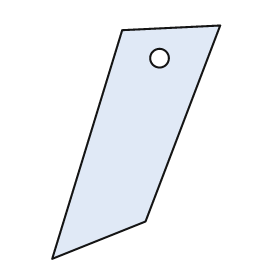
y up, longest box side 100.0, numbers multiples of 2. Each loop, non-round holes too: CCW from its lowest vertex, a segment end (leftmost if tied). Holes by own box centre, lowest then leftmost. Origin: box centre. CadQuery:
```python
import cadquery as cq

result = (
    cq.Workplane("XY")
    .moveTo(-36.0, -50.0)
    .lineTo(4.0, -34.0)
    .lineTo(36.0, 50.0)
    .lineTo(-6.0, 48.0)
    .close()
    .moveTo(10.0, 36.0)
    .circle(4.0)
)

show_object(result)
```